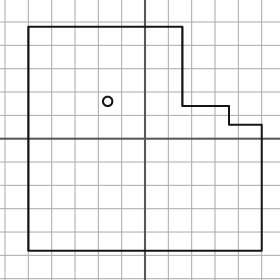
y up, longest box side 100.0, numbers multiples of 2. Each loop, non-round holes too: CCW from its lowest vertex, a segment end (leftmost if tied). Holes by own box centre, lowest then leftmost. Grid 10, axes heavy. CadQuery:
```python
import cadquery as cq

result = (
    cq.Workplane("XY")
    .moveTo(-50.0, -48.0)
    .lineTo(50.0, -48.0)
    .lineTo(50.0, 6.0)
    .lineTo(36.0, 6.0)
    .lineTo(36.0, 14.0)
    .lineTo(16.0, 14.0)
    .lineTo(16.0, 48.0)
    .lineTo(-50.0, 48.0)
    .close()
    .moveTo(-16.0, 16.0)
    .circle(2.0)
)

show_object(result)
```